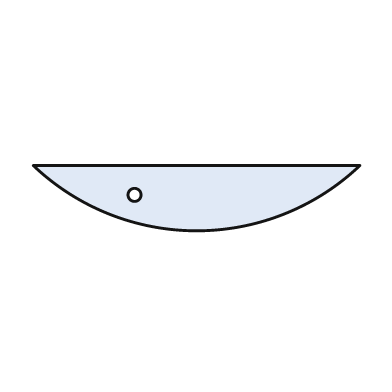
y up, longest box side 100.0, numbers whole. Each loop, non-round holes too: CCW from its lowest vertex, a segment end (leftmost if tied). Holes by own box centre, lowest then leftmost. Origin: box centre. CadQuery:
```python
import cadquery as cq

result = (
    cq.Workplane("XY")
    .moveTo(-50.0, 10.0)
    .threePointArc((0.0, -10.0), (50.0, 10.0))
    .close()
    .moveTo(-19.0, 1.0)
    .circle(2.0)
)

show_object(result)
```